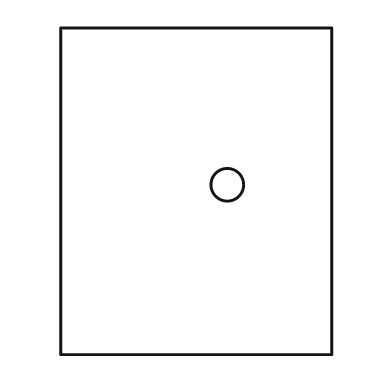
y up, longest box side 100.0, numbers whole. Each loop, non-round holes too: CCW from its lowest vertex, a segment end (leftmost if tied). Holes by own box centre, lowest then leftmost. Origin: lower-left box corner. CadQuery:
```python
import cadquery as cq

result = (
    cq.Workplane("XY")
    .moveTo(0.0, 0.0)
    .lineTo(83.0, 0.0)
    .lineTo(83.0, 100.0)
    .lineTo(0.0, 100.0)
    .close()
    .moveTo(51.0, 52.0)
    .circle(5.0)
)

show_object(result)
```